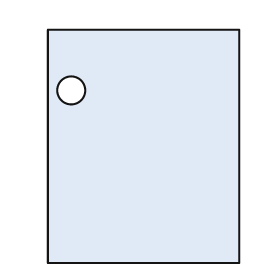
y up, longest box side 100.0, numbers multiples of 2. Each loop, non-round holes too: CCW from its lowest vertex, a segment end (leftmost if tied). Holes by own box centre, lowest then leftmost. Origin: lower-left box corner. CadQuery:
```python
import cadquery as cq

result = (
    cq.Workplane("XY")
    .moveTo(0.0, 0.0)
    .lineTo(82.0, 0.0)
    .lineTo(82.0, 100.0)
    .lineTo(0.0, 100.0)
    .close()
    .moveTo(10.0, 74.0)
    .circle(6.0)
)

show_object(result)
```